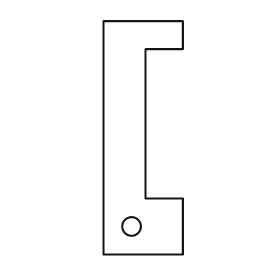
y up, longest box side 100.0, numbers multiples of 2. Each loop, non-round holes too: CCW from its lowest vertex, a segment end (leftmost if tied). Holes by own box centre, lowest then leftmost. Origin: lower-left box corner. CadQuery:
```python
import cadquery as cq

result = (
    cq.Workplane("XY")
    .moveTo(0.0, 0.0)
    .lineTo(34.0, 0.0)
    .lineTo(34.0, 24.0)
    .lineTo(18.0, 24.0)
    .lineTo(18.0, 88.0)
    .lineTo(34.0, 88.0)
    .lineTo(34.0, 100.0)
    .lineTo(0.0, 100.0)
    .close()
    .moveTo(12.0, 12.0)
    .circle(4.0)
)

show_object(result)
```